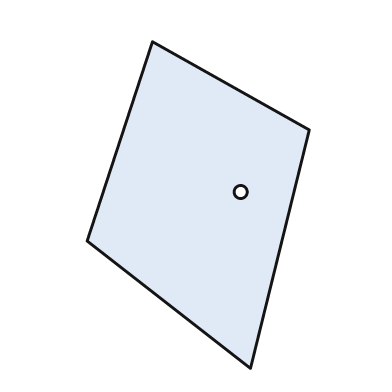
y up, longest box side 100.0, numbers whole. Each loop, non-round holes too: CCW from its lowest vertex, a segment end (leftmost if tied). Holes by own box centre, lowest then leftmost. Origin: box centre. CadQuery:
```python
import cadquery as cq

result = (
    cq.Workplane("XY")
    .moveTo(16.0, -50.0)
    .lineTo(34.0, 23.0)
    .lineTo(-14.0, 50.0)
    .lineTo(-34.0, -11.0)
    .close()
    .moveTo(13.0, 4.0)
    .circle(2.0)
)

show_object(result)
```